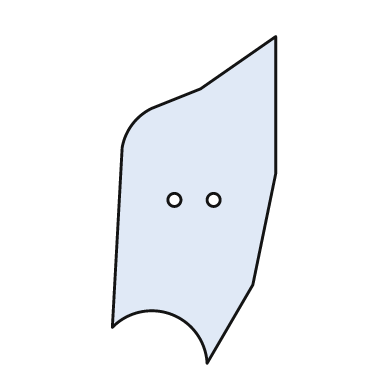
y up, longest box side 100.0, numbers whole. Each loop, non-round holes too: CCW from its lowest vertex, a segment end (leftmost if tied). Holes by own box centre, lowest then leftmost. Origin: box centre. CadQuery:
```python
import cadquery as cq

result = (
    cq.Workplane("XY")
    .moveTo(4.0, -50.0)
    .lineTo(18.0, -26.0)
    .lineTo(25.0, 8.0)
    .lineTo(25.0, 50.0)
    .lineTo(2.0, 34.0)
    .lineTo(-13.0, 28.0)
    .threePointArc((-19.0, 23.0), (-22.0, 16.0))
    .lineTo(-25.0, -39.0)
    .threePointArc((-7.0, -35.0), (4.0, -50.0))
    .close()
    .moveTo(-6.0, 0.0)
    .circle(2.0)
    .moveTo(6.0, 0.0)
    .circle(2.0)
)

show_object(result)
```